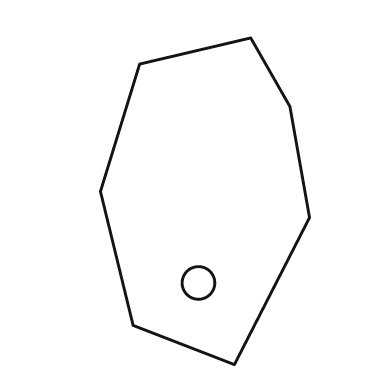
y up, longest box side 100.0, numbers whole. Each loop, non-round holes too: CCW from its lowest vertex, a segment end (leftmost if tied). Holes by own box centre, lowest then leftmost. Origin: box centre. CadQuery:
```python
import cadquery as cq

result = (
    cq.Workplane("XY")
    .moveTo(9.0, -50.0)
    .lineTo(32.0, -5.0)
    .lineTo(26.0, 29.0)
    .lineTo(14.0, 50.0)
    .lineTo(-20.0, 42.0)
    .lineTo(-32.0, 3.0)
    .lineTo(-22.0, -38.0)
    .close()
    .moveTo(-2.0, -25.0)
    .circle(5.0)
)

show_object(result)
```